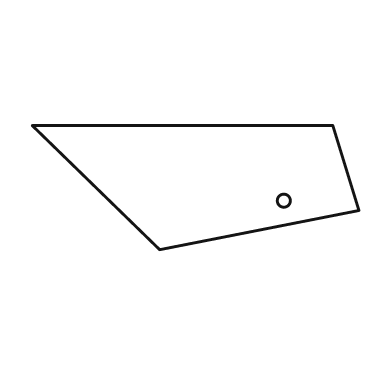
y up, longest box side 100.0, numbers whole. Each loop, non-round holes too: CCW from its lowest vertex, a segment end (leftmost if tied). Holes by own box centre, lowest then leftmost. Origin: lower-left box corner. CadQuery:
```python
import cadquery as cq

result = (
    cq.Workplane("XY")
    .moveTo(39.0, 0.0)
    .lineTo(100.0, 12.0)
    .lineTo(92.0, 38.0)
    .lineTo(0.0, 38.0)
    .close()
    .moveTo(77.0, 15.0)
    .circle(2.0)
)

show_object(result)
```